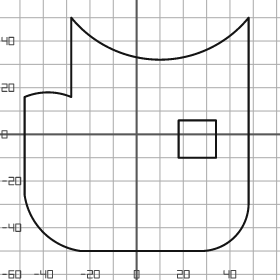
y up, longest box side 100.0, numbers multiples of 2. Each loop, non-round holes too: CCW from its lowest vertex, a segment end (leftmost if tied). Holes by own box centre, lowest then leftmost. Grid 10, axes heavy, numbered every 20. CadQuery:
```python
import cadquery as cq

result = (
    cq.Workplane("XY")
    .moveTo(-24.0, -50.0)
    .lineTo(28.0, -50.0)
    .threePointArc((42.0, -44.0), (48.0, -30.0))
    .lineTo(48.0, 50.0)
    .threePointArc((10.0, 32.0), (-28.0, 50.0))
    .lineTo(-28.0, 16.0)
    .threePointArc((-38.0, 18.0), (-48.0, 16.0))
    .lineTo(-48.0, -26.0)
    .threePointArc((-40.0, -42.0), (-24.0, -50.0))
    .close()
    .moveTo(18.0, -10.0)
    .lineTo(34.0, -10.0)
    .lineTo(34.0, 6.0)
    .lineTo(18.0, 6.0)
    .close()
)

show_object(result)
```